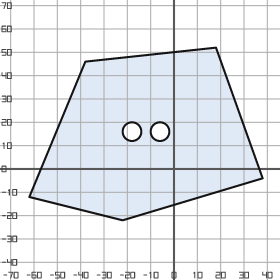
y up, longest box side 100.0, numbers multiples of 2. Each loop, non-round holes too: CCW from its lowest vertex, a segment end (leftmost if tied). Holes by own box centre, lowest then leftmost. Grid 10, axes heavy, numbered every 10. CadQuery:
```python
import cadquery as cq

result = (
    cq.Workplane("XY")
    .moveTo(-22.0, -22.0)
    .lineTo(38.0, -4.0)
    .lineTo(18.0, 52.0)
    .lineTo(-38.0, 46.0)
    .lineTo(-62.0, -12.0)
    .close()
    .moveTo(-18.0, 16.0)
    .circle(4.0)
    .moveTo(-6.0, 16.0)
    .circle(4.0)
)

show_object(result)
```